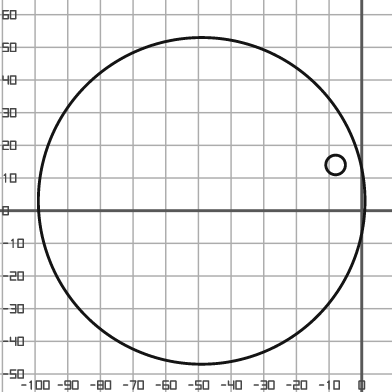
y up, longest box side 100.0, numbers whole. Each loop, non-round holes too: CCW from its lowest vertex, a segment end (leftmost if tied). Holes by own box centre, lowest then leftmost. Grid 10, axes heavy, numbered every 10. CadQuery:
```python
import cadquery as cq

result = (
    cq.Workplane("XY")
    .moveTo(-49.0, 3.0)
    .circle(50.0)
    .moveTo(-8.0, 14.0)
    .circle(3.0)
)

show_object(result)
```